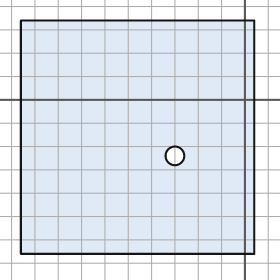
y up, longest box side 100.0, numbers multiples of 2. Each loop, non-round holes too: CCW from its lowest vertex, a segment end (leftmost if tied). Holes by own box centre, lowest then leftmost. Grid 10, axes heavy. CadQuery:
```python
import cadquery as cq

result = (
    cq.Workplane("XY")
    .moveTo(-96.0, -66.0)
    .lineTo(4.0, -66.0)
    .lineTo(4.0, 34.0)
    .lineTo(-96.0, 34.0)
    .close()
    .moveTo(-30.0, -24.0)
    .circle(4.0)
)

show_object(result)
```